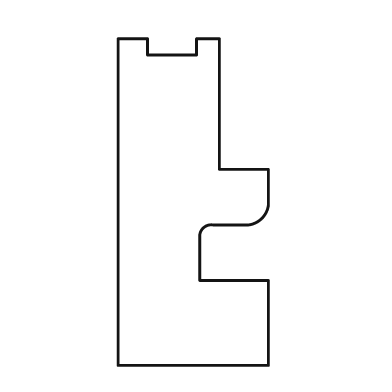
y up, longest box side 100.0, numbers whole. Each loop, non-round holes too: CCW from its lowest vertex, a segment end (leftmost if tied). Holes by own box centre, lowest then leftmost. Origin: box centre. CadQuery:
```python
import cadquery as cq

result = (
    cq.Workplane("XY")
    .moveTo(-23.0, -50.0)
    .lineTo(23.0, -50.0)
    .lineTo(23.0, -24.0)
    .lineTo(2.0, -24.0)
    .lineTo(2.0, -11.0)
    .threePointArc((3.0, -8.0), (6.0, -7.0))
    .lineTo(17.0, -7.0)
    .threePointArc((21.0, -5.0), (23.0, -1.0))
    .lineTo(23.0, 10.0)
    .lineTo(8.0, 10.0)
    .lineTo(8.0, 50.0)
    .lineTo(1.0, 50.0)
    .lineTo(1.0, 45.0)
    .lineTo(-14.0, 45.0)
    .lineTo(-14.0, 50.0)
    .lineTo(-23.0, 50.0)
    .close()
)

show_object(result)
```